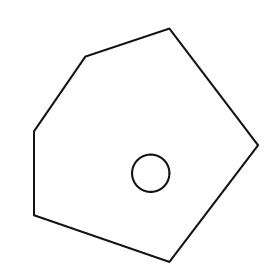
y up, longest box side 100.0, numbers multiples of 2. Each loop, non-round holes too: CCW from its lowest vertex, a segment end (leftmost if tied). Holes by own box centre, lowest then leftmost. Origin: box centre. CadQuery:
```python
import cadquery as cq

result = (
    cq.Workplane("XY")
    .moveTo(10.0, -50.0)
    .lineTo(48.0, 0.0)
    .lineTo(10.0, 50.0)
    .lineTo(-26.0, 38.0)
    .lineTo(-48.0, 6.0)
    .lineTo(-48.0, -30.0)
    .close()
    .moveTo(2.0, -12.0)
    .circle(8.0)
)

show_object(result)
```